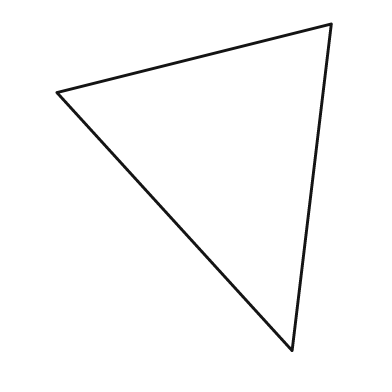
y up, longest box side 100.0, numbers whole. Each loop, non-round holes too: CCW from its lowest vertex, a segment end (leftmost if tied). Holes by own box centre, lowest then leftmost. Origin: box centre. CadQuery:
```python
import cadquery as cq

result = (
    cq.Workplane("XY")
    .moveTo(30.0, -50.0)
    .lineTo(42.0, 50.0)
    .lineTo(-42.0, 29.0)
    .close()
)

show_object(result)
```